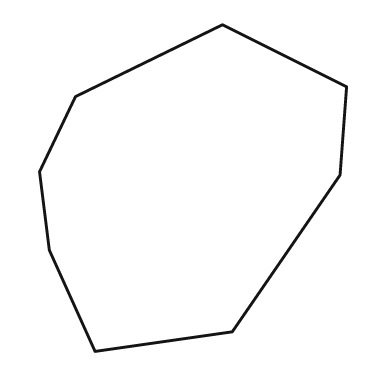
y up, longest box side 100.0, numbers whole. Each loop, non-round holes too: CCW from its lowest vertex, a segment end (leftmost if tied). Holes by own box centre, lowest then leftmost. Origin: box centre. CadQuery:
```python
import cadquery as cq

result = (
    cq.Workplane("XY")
    .moveTo(-30.0, -50.0)
    .lineTo(12.0, -44.0)
    .lineTo(45.0, 4.0)
    .lineTo(47.0, 31.0)
    .lineTo(9.0, 50.0)
    .lineTo(-36.0, 28.0)
    .lineTo(-47.0, 5.0)
    .lineTo(-44.0, -19.0)
    .close()
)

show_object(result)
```